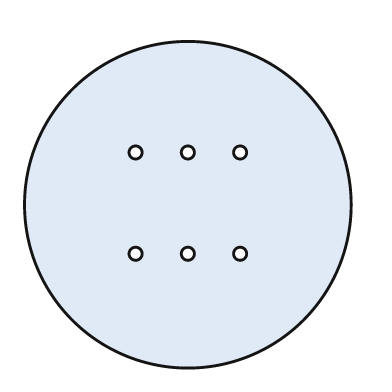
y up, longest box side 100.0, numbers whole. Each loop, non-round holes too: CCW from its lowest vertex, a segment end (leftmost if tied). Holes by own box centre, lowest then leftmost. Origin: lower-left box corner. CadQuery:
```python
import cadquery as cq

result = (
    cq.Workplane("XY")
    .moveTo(50.0, 50.0)
    .circle(50.0)
    .moveTo(34.0, 35.0)
    .circle(2.0)
    .moveTo(50.0, 35.0)
    .circle(2.0)
    .moveTo(66.0, 35.0)
    .circle(2.0)
    .moveTo(34.0, 66.0)
    .circle(2.0)
    .moveTo(50.0, 66.0)
    .circle(2.0)
    .moveTo(66.0, 66.0)
    .circle(2.0)
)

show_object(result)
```